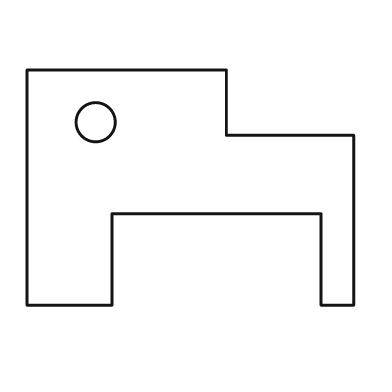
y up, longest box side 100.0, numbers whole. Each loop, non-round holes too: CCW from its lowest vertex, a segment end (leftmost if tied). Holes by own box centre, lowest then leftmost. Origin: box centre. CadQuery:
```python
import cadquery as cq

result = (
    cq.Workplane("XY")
    .moveTo(-50.0, -36.0)
    .lineTo(-24.0, -36.0)
    .lineTo(-24.0, -8.0)
    .lineTo(40.0, -8.0)
    .lineTo(40.0, -36.0)
    .lineTo(50.0, -36.0)
    .lineTo(50.0, 16.0)
    .lineTo(11.0, 16.0)
    .lineTo(11.0, 36.0)
    .lineTo(-50.0, 36.0)
    .close()
    .moveTo(-29.0, 20.0)
    .circle(6.0)
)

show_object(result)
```